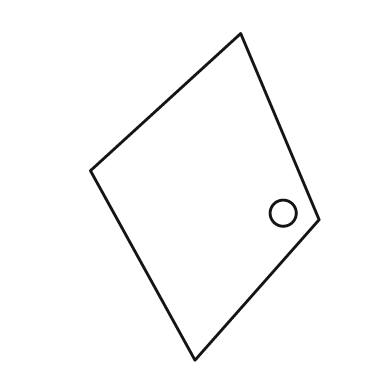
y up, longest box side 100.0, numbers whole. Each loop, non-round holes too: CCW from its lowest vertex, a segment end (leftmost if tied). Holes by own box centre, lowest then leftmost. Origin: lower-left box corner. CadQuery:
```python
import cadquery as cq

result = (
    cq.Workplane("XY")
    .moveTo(32.0, 0.0)
    .lineTo(70.0, 43.0)
    .lineTo(46.0, 100.0)
    .lineTo(0.0, 58.0)
    .close()
    .moveTo(59.0, 45.0)
    .circle(4.0)
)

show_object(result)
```